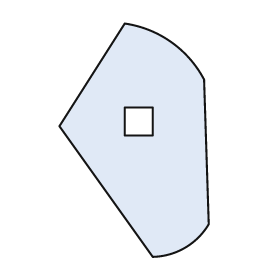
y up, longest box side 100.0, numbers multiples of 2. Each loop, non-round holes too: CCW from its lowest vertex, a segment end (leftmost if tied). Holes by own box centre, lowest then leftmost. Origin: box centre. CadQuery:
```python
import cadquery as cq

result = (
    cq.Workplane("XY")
    .moveTo(8.0, -50.0)
    .threePointArc((22.0, -46.0), (32.0, -36.0))
    .lineTo(30.0, 26.0)
    .threePointArc((16.0, 42.0), (-4.0, 50.0))
    .lineTo(-32.0, 6.0)
    .close()
    .moveTo(-4.0, 2.0)
    .lineTo(8.0, 2.0)
    .lineTo(8.0, 14.0)
    .lineTo(-4.0, 14.0)
    .close()
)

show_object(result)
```